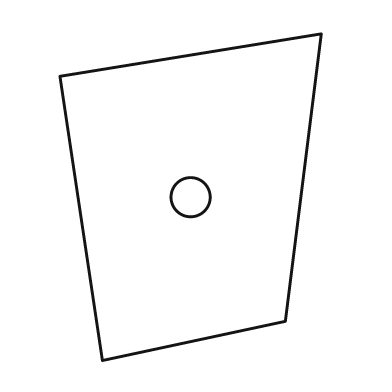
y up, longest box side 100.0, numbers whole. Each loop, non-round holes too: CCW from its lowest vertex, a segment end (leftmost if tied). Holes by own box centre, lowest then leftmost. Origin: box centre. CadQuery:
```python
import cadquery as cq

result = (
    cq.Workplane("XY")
    .moveTo(-27.0, -50.0)
    .lineTo(29.0, -38.0)
    .lineTo(40.0, 50.0)
    .lineTo(-40.0, 37.0)
    .close()
    .moveTo(0.0, 0.0)
    .circle(6.0)
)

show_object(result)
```